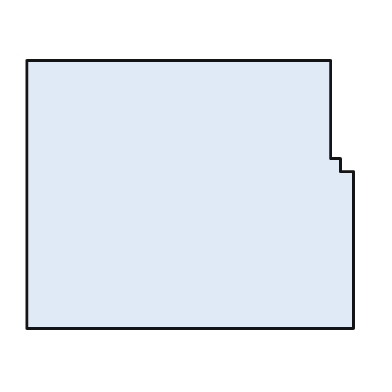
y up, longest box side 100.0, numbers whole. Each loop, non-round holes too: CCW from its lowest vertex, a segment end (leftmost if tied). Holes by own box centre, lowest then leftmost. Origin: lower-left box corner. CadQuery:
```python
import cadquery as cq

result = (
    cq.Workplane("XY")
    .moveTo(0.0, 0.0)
    .lineTo(100.0, 0.0)
    .lineTo(100.0, 48.0)
    .lineTo(96.0, 48.0)
    .lineTo(96.0, 52.0)
    .lineTo(93.0, 52.0)
    .lineTo(93.0, 82.0)
    .lineTo(0.0, 82.0)
    .close()
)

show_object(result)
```